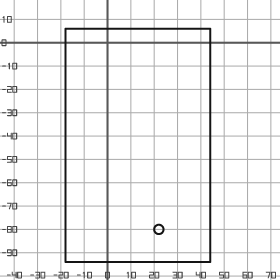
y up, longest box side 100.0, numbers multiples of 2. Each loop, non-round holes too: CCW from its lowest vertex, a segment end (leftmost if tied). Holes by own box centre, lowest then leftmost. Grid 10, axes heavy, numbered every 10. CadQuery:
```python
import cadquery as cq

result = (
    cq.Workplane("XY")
    .moveTo(-18.0, -94.0)
    .lineTo(44.0, -94.0)
    .lineTo(44.0, 6.0)
    .lineTo(-18.0, 6.0)
    .close()
    .moveTo(22.0, -80.0)
    .circle(2.0)
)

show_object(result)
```